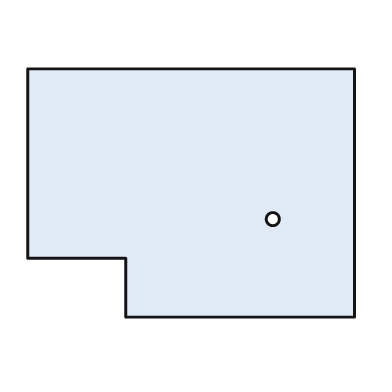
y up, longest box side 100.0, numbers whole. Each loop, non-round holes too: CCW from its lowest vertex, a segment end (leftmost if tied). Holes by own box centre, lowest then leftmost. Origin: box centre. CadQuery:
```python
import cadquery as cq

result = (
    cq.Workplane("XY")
    .moveTo(-20.0, -38.0)
    .lineTo(50.0, -38.0)
    .lineTo(50.0, 38.0)
    .lineTo(-50.0, 38.0)
    .lineTo(-50.0, -20.0)
    .lineTo(-20.0, -20.0)
    .close()
    .moveTo(25.0, -8.0)
    .circle(2.0)
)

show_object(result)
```